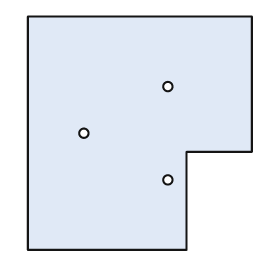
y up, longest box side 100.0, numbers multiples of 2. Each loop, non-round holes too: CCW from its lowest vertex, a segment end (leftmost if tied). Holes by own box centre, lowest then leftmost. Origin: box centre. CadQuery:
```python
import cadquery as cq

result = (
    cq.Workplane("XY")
    .moveTo(-48.0, -50.0)
    .lineTo(20.0, -50.0)
    .lineTo(20.0, -8.0)
    .lineTo(48.0, -8.0)
    .lineTo(48.0, 50.0)
    .lineTo(-48.0, 50.0)
    .close()
    .moveTo(12.0, -20.0)
    .circle(2.0)
    .moveTo(-24.0, 0.0)
    .circle(2.0)
    .moveTo(12.0, 20.0)
    .circle(2.0)
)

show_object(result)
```